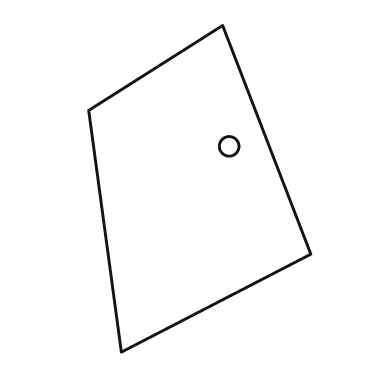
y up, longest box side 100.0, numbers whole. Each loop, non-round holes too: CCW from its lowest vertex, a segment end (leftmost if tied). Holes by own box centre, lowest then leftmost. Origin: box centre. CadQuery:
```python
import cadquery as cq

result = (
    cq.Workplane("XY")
    .moveTo(-24.0, -50.0)
    .lineTo(34.0, -20.0)
    .lineTo(7.0, 50.0)
    .lineTo(-34.0, 24.0)
    .close()
    .moveTo(9.0, 13.0)
    .circle(3.0)
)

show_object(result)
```